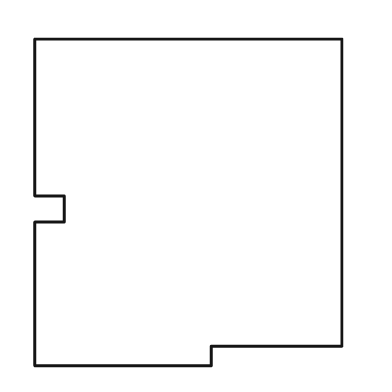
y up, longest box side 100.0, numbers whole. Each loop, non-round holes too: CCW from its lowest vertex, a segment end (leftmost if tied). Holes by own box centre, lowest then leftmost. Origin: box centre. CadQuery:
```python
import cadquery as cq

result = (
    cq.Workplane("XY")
    .moveTo(-47.0, -50.0)
    .lineTo(7.0, -50.0)
    .lineTo(7.0, -44.0)
    .lineTo(47.0, -44.0)
    .lineTo(47.0, 50.0)
    .lineTo(-47.0, 50.0)
    .lineTo(-47.0, 2.0)
    .lineTo(-38.0, 2.0)
    .lineTo(-38.0, -6.0)
    .lineTo(-47.0, -6.0)
    .close()
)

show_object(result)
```